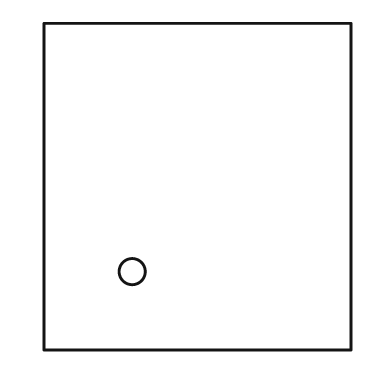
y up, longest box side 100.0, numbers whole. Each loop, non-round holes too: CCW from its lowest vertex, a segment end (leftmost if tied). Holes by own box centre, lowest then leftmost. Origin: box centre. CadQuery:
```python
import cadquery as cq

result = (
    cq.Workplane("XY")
    .moveTo(-47.0, -50.0)
    .lineTo(47.0, -50.0)
    .lineTo(47.0, 50.0)
    .lineTo(-47.0, 50.0)
    .close()
    .moveTo(-20.0, -26.0)
    .circle(4.0)
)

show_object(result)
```